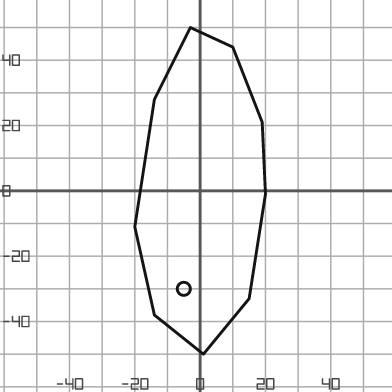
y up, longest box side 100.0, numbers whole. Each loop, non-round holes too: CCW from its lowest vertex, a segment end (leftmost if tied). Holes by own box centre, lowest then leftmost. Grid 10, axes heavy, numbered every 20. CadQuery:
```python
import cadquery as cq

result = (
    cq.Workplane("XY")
    .moveTo(1.0, -50.0)
    .lineTo(15.0, -33.0)
    .lineTo(20.0, -1.0)
    .lineTo(19.0, 21.0)
    .lineTo(10.0, 44.0)
    .lineTo(-3.0, 50.0)
    .lineTo(-14.0, 28.0)
    .lineTo(-20.0, -11.0)
    .lineTo(-14.0, -38.0)
    .close()
    .moveTo(-5.0, -30.0)
    .circle(2.0)
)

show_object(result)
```